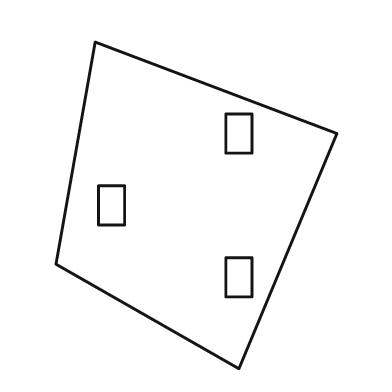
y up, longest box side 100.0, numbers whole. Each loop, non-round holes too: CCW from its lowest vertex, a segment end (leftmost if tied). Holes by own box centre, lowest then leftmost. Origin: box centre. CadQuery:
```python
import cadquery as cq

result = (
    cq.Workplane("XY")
    .moveTo(13.0, -50.0)
    .lineTo(43.0, 22.0)
    .lineTo(-31.0, 50.0)
    .lineTo(-43.0, -18.0)
    .close()
    .moveTo(9.0, -28.0)
    .lineTo(17.0, -28.0)
    .lineTo(17.0, -16.0)
    .lineTo(9.0, -16.0)
    .close()
    .moveTo(-30.0, -6.0)
    .lineTo(-22.0, -6.0)
    .lineTo(-22.0, 6.0)
    .lineTo(-30.0, 6.0)
    .close()
    .moveTo(9.0, 16.0)
    .lineTo(17.0, 16.0)
    .lineTo(17.0, 28.0)
    .lineTo(9.0, 28.0)
    .close()
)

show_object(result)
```